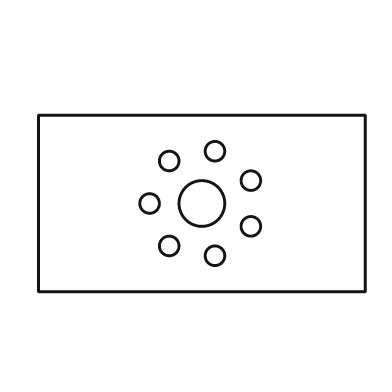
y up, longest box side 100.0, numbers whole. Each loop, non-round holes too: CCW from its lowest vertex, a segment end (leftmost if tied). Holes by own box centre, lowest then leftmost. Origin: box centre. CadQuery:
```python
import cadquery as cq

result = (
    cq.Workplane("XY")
    .moveTo(-50.0, -27.0)
    .lineTo(50.0, -27.0)
    .lineTo(50.0, 27.0)
    .lineTo(-50.0, 27.0)
    .close()
    .moveTo(4.0, -16.0)
    .circle(3.0)
    .moveTo(-10.0, -13.0)
    .circle(3.0)
    .moveTo(15.0, -7.0)
    .circle(3.0)
    .moveTo(-16.0, 0.0)
    .circle(3.0)
    .moveTo(0.0, 0.0)
    .circle(7.0)
    .moveTo(15.0, 7.0)
    .circle(3.0)
    .moveTo(-10.0, 13.0)
    .circle(3.0)
    .moveTo(4.0, 16.0)
    .circle(3.0)
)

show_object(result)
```